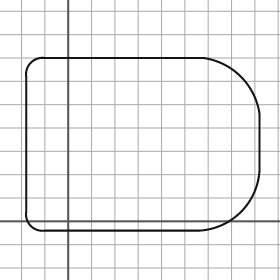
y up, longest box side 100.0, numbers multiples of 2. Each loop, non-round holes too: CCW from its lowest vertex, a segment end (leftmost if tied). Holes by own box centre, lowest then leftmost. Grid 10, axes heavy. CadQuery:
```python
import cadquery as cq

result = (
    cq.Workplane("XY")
    .moveTo(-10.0, -4.0)
    .lineTo(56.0, -4.0)
    .threePointArc((74.0, 4.0), (82.0, 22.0))
    .lineTo(82.0, 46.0)
    .threePointArc((74.0, 62.0), (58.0, 70.0))
    .lineTo(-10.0, 70.0)
    .threePointArc((-16.0, 68.0), (-18.0, 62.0))
    .lineTo(-18.0, 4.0)
    .threePointArc((-16.0, -2.0), (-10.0, -4.0))
    .close()
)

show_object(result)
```